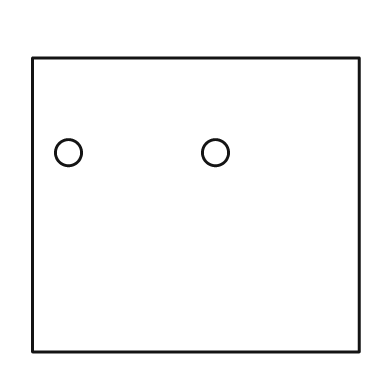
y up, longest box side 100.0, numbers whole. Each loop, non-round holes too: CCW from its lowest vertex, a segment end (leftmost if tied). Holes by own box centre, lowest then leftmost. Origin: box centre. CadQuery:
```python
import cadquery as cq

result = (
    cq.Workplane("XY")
    .moveTo(-50.0, -45.0)
    .lineTo(50.0, -45.0)
    .lineTo(50.0, 45.0)
    .lineTo(-50.0, 45.0)
    .close()
    .moveTo(-39.0, 16.0)
    .circle(4.0)
    .moveTo(6.0, 16.0)
    .circle(4.0)
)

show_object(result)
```